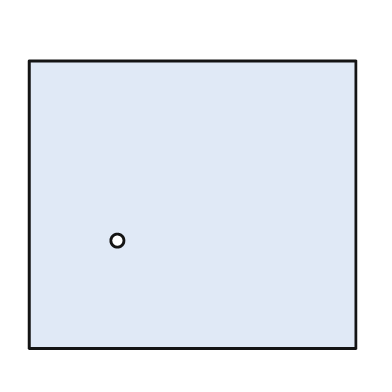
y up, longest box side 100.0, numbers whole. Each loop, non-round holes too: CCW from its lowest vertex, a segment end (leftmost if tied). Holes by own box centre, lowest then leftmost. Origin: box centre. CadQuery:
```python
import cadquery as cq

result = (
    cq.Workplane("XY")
    .moveTo(-50.0, -44.0)
    .lineTo(50.0, -44.0)
    .lineTo(50.0, 44.0)
    .lineTo(-50.0, 44.0)
    .close()
    .moveTo(-23.0, -11.0)
    .circle(2.0)
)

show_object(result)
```